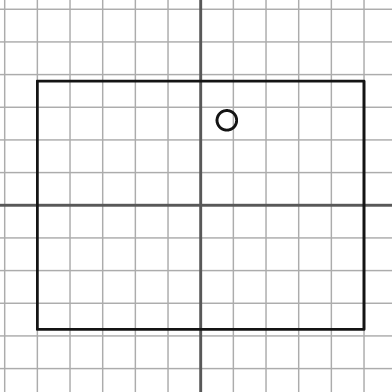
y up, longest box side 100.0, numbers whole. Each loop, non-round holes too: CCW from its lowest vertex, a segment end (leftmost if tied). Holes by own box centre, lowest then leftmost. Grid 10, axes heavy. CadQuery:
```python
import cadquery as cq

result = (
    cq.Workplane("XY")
    .moveTo(-50.0, -38.0)
    .lineTo(50.0, -38.0)
    .lineTo(50.0, 38.0)
    .lineTo(-50.0, 38.0)
    .close()
    .moveTo(8.0, 26.0)
    .circle(3.0)
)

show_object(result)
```